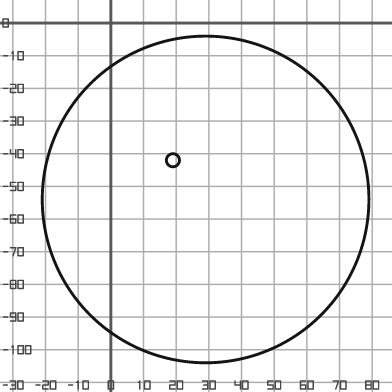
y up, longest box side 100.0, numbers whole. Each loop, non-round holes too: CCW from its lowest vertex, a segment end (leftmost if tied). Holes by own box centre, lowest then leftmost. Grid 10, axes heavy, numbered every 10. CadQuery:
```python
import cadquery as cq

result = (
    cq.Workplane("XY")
    .moveTo(29.0, -54.0)
    .circle(50.0)
    .moveTo(19.0, -42.0)
    .circle(2.0)
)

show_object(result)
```